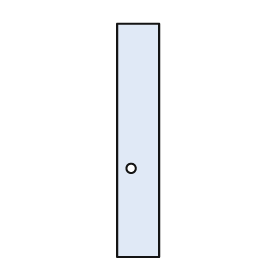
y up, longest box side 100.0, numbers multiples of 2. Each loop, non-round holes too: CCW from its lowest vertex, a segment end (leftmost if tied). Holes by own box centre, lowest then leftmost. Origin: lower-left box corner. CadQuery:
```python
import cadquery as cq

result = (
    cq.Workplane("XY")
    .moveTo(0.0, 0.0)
    .lineTo(18.0, 0.0)
    .lineTo(18.0, 100.0)
    .lineTo(0.0, 100.0)
    .close()
    .moveTo(6.0, 38.0)
    .circle(2.0)
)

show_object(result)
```